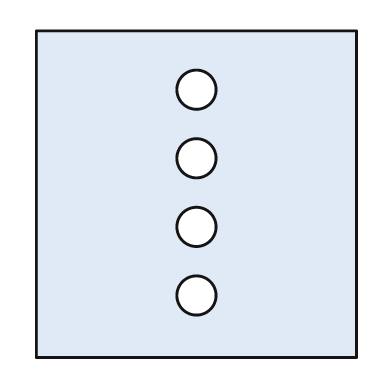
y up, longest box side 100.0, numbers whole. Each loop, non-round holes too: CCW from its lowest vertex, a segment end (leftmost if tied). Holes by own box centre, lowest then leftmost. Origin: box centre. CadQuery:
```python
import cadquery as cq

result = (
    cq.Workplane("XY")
    .moveTo(-49.0, -50.0)
    .lineTo(49.0, -50.0)
    .lineTo(49.0, 50.0)
    .lineTo(-49.0, 50.0)
    .close()
    .moveTo(0.0, -31.0)
    .circle(6.0)
    .moveTo(0.0, -10.0)
    .circle(6.0)
    .moveTo(0.0, 11.0)
    .circle(6.0)
    .moveTo(0.0, 32.0)
    .circle(6.0)
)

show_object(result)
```